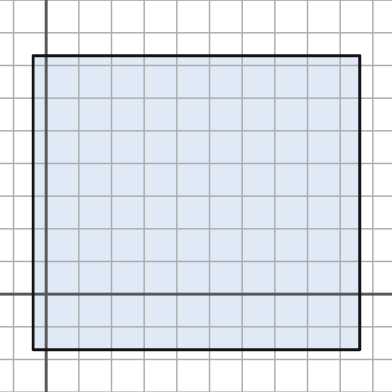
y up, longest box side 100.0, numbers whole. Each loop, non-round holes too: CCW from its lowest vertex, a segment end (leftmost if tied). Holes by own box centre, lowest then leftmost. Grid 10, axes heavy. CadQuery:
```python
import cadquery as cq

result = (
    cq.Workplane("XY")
    .moveTo(-4.0, -17.0)
    .lineTo(96.0, -17.0)
    .lineTo(96.0, 73.0)
    .lineTo(-4.0, 73.0)
    .close()
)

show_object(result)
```